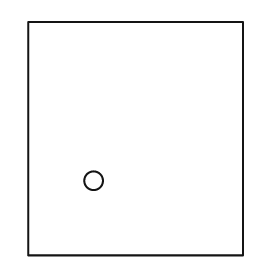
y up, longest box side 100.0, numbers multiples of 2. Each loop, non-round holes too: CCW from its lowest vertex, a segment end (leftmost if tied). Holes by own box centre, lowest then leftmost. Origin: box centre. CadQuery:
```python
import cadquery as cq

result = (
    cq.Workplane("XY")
    .moveTo(-46.0, -50.0)
    .lineTo(46.0, -50.0)
    .lineTo(46.0, 50.0)
    .lineTo(-46.0, 50.0)
    .close()
    .moveTo(-18.0, -18.0)
    .circle(4.0)
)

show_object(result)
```